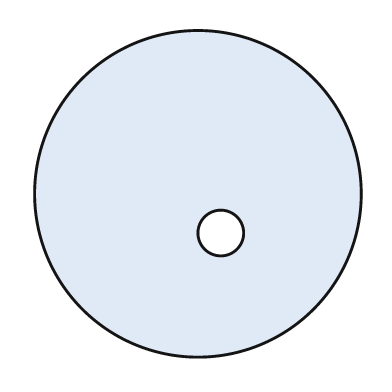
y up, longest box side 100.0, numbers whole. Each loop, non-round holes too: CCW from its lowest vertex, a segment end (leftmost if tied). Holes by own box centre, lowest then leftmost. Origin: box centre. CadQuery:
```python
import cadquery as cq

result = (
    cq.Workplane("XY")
    .moveTo(0.0, 0.0)
    .circle(50.0)
    .moveTo(7.0, -12.0)
    .circle(7.0)
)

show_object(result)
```